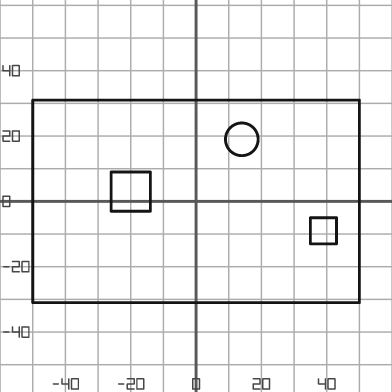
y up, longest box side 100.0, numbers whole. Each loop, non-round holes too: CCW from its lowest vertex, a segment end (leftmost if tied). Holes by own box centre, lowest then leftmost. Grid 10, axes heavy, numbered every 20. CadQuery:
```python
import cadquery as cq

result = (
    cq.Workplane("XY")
    .moveTo(-50.0, -31.0)
    .lineTo(50.0, -31.0)
    .lineTo(50.0, 31.0)
    .lineTo(-50.0, 31.0)
    .close()
    .moveTo(35.0, -13.0)
    .lineTo(43.0, -13.0)
    .lineTo(43.0, -5.0)
    .lineTo(35.0, -5.0)
    .close()
    .moveTo(-26.0, -3.0)
    .lineTo(-14.0, -3.0)
    .lineTo(-14.0, 9.0)
    .lineTo(-26.0, 9.0)
    .close()
    .moveTo(14.0, 19.0)
    .circle(5.0)
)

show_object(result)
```